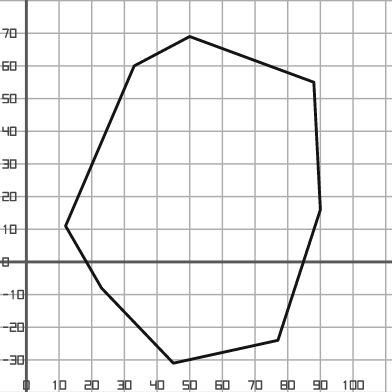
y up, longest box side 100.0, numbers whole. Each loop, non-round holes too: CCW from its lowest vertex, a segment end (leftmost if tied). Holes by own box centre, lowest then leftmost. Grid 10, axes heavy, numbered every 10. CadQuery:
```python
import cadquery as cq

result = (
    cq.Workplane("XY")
    .moveTo(45.0, -31.0)
    .lineTo(77.0, -24.0)
    .lineTo(90.0, 16.0)
    .lineTo(88.0, 55.0)
    .lineTo(50.0, 69.0)
    .lineTo(33.0, 60.0)
    .lineTo(12.0, 11.0)
    .lineTo(23.0, -8.0)
    .close()
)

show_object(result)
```